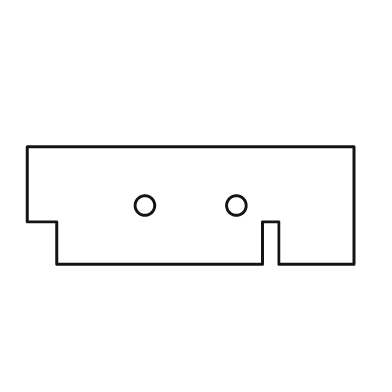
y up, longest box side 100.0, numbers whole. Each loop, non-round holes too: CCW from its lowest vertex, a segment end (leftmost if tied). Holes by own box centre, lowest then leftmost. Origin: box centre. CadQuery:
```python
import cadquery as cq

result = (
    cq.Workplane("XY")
    .moveTo(-41.0, -18.0)
    .lineTo(22.0, -18.0)
    .lineTo(22.0, -5.0)
    .lineTo(27.0, -5.0)
    .lineTo(27.0, -18.0)
    .lineTo(50.0, -18.0)
    .lineTo(50.0, 18.0)
    .lineTo(-50.0, 18.0)
    .lineTo(-50.0, -5.0)
    .lineTo(-41.0, -5.0)
    .close()
    .moveTo(-14.0, 0.0)
    .circle(3.0)
    .moveTo(14.0, 0.0)
    .circle(3.0)
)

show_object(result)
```